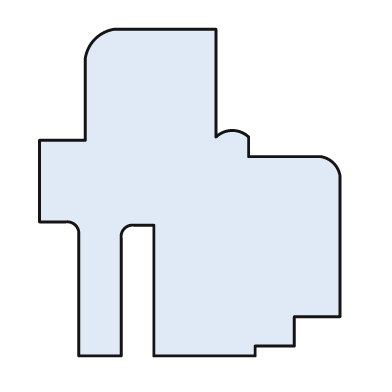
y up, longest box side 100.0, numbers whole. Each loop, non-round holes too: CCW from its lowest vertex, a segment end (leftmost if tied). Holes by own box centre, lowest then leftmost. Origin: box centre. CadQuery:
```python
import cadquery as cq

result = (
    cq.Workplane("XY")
    .moveTo(-34.0, -50.0)
    .lineTo(-21.0, -50.0)
    .lineTo(-21.0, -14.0)
    .threePointArc((-20.0, -11.0), (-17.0, -10.0))
    .lineTo(-11.0, -10.0)
    .lineTo(-11.0, -50.0)
    .lineTo(20.0, -50.0)
    .lineTo(20.0, -47.0)
    .lineTo(32.0, -47.0)
    .lineTo(32.0, -38.0)
    .lineTo(46.0, -38.0)
    .lineTo(46.0, 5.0)
    .threePointArc((44.0, 9.0), (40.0, 11.0))
    .lineTo(18.0, 11.0)
    .lineTo(18.0, 17.0)
    .threePointArc((13.0, 19.0), (8.0, 17.0))
    .lineTo(8.0, 50.0)
    .lineTo(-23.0, 50.0)
    .threePointArc((-29.0, 47.0), (-32.0, 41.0))
    .lineTo(-32.0, 16.0)
    .lineTo(-46.0, 16.0)
    .lineTo(-46.0, -9.0)
    .lineTo(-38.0, -9.0)
    .threePointArc((-35.0, -10.0), (-34.0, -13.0))
    .close()
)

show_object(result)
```